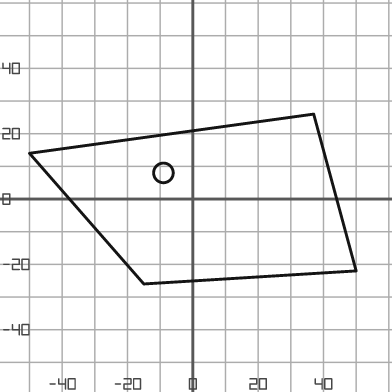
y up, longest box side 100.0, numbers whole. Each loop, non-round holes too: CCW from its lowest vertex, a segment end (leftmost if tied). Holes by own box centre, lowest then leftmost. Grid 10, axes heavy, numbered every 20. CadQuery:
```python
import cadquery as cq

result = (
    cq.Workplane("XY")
    .moveTo(-15.0, -26.0)
    .lineTo(50.0, -22.0)
    .lineTo(37.0, 26.0)
    .lineTo(-50.0, 14.0)
    .close()
    .moveTo(-9.0, 8.0)
    .circle(3.0)
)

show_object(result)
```